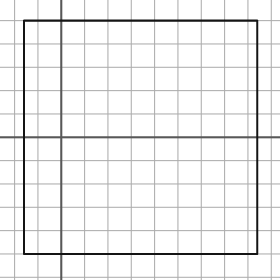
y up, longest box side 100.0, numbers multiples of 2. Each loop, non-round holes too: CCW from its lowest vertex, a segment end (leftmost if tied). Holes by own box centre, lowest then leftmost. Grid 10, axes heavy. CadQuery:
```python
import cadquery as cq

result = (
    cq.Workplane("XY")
    .moveTo(-16.0, -50.0)
    .lineTo(84.0, -50.0)
    .lineTo(84.0, 50.0)
    .lineTo(-16.0, 50.0)
    .close()
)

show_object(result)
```